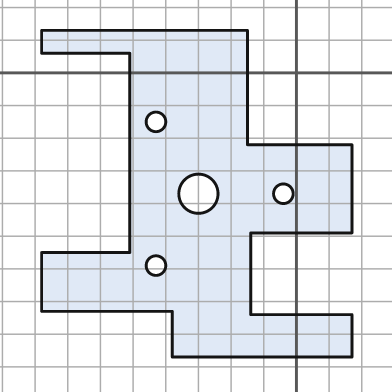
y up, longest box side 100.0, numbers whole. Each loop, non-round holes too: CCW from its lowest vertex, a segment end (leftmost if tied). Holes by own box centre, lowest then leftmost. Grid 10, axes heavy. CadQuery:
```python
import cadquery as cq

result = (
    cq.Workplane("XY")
    .moveTo(-38.0, -87.0)
    .lineTo(17.0, -87.0)
    .lineTo(17.0, -74.0)
    .lineTo(-14.0, -74.0)
    .lineTo(-14.0, -49.0)
    .lineTo(17.0, -49.0)
    .lineTo(17.0, -22.0)
    .lineTo(-15.0, -22.0)
    .lineTo(-15.0, 13.0)
    .lineTo(-78.0, 13.0)
    .lineTo(-78.0, 6.0)
    .lineTo(-51.0, 6.0)
    .lineTo(-51.0, -55.0)
    .lineTo(-78.0, -55.0)
    .lineTo(-78.0, -73.0)
    .lineTo(-38.0, -73.0)
    .close()
    .moveTo(-43.0, -59.0)
    .circle(3.0)
    .moveTo(-30.0, -37.0)
    .circle(6.0)
    .moveTo(-4.0, -37.0)
    .circle(3.0)
    .moveTo(-43.0, -15.0)
    .circle(3.0)
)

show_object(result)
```